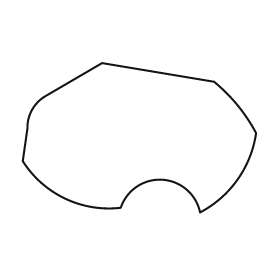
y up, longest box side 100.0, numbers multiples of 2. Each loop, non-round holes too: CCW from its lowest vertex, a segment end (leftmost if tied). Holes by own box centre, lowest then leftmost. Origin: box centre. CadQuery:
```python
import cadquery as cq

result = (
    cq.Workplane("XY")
    .moveTo(26.0, -32.0)
    .threePointArc((42.0, -18.0), (50.0, 2.0))
    .threePointArc((42.0, 14.0), (32.0, 24.0))
    .lineTo(-16.0, 32.0)
    .lineTo(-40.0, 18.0)
    .threePointArc((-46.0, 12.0), (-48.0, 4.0))
    .lineTo(-50.0, -10.0)
    .threePointArc((-32.0, -26.0), (-8.0, -30.0))
    .threePointArc((10.0, -18.0), (26.0, -32.0))
    .close()
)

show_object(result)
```